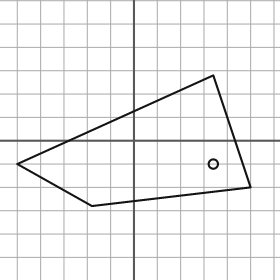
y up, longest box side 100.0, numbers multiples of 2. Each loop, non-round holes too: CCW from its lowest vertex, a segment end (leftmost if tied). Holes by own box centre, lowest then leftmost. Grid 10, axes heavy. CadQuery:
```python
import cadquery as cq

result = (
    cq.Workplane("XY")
    .moveTo(-18.0, -28.0)
    .lineTo(50.0, -20.0)
    .lineTo(34.0, 28.0)
    .lineTo(-50.0, -10.0)
    .close()
    .moveTo(34.0, -10.0)
    .circle(2.0)
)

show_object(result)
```